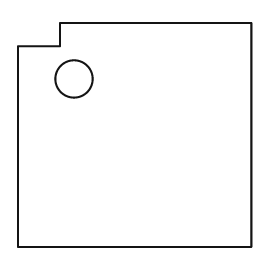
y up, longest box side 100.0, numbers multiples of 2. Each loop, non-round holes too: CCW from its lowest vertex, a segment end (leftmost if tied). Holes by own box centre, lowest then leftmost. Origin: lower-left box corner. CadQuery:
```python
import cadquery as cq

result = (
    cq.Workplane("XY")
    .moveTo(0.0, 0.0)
    .lineTo(100.0, 0.0)
    .lineTo(100.0, 96.0)
    .lineTo(18.0, 96.0)
    .lineTo(18.0, 86.0)
    .lineTo(0.0, 86.0)
    .close()
    .moveTo(24.0, 72.0)
    .circle(8.0)
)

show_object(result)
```